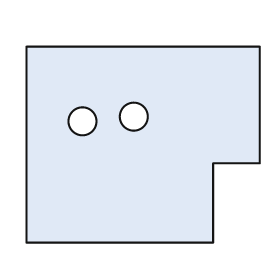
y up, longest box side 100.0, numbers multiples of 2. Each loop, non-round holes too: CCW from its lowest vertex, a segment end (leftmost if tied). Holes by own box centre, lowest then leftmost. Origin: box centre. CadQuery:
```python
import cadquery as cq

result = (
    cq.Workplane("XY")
    .moveTo(-50.0, -42.0)
    .lineTo(30.0, -42.0)
    .lineTo(30.0, -8.0)
    .lineTo(50.0, -8.0)
    .lineTo(50.0, 42.0)
    .lineTo(-50.0, 42.0)
    .close()
    .moveTo(-26.0, 10.0)
    .circle(6.0)
    .moveTo(-4.0, 12.0)
    .circle(6.0)
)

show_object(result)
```